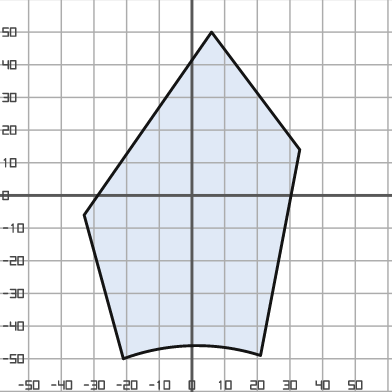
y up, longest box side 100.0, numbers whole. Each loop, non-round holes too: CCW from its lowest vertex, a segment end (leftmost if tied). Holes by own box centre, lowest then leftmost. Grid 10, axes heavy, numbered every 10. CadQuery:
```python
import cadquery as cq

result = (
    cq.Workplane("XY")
    .moveTo(-21.0, -50.0)
    .threePointArc((0.0, -46.0), (21.0, -49.0))
    .lineTo(33.0, 14.0)
    .lineTo(6.0, 50.0)
    .lineTo(-33.0, -6.0)
    .close()
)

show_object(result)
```